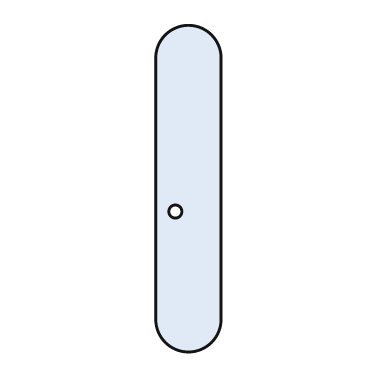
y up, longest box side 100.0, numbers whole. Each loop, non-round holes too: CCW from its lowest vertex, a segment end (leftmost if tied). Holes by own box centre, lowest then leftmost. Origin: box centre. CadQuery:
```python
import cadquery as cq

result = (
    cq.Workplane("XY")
    .moveTo(-10.0, -40.0)
    .threePointArc((0.0, -50.0), (10.0, -40.0))
    .lineTo(10.0, 40.0)
    .threePointArc((0.0, 50.0), (-10.0, 40.0))
    .close()
    .moveTo(-4.0, -7.0)
    .circle(2.0)
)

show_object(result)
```